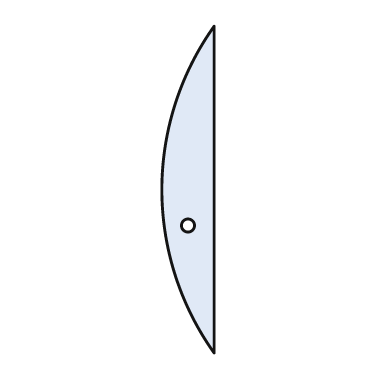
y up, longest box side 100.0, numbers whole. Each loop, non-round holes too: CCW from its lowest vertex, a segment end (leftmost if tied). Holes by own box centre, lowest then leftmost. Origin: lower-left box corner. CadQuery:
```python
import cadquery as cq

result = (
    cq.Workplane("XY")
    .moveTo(16.0, 0.0)
    .lineTo(16.0, 100.0)
    .threePointArc((0.0, 50.0), (16.0, 0.0))
    .close()
    .moveTo(8.0, 39.0)
    .circle(2.0)
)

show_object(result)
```